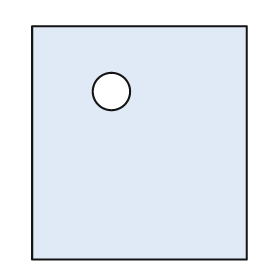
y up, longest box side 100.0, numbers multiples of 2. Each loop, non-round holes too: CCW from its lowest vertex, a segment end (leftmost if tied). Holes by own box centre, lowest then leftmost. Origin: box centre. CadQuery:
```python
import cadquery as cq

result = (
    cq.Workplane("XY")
    .moveTo(-46.0, -50.0)
    .lineTo(46.0, -50.0)
    .lineTo(46.0, 50.0)
    .lineTo(-46.0, 50.0)
    .close()
    .moveTo(-12.0, 22.0)
    .circle(8.0)
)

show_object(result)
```